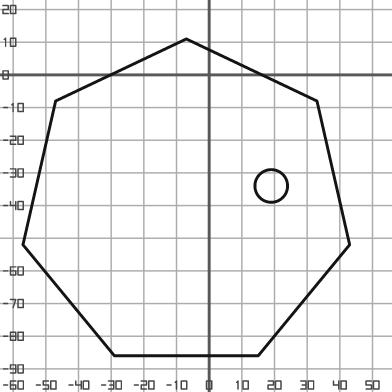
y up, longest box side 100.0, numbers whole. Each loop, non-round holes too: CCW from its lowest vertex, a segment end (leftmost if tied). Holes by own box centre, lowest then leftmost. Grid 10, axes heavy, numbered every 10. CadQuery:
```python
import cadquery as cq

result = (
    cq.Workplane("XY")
    .moveTo(-29.0, -86.0)
    .lineTo(15.0, -86.0)
    .lineTo(43.0, -52.0)
    .lineTo(33.0, -8.0)
    .lineTo(-7.0, 11.0)
    .lineTo(-47.0, -8.0)
    .lineTo(-57.0, -52.0)
    .close()
    .moveTo(19.0, -34.0)
    .circle(5.0)
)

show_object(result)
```